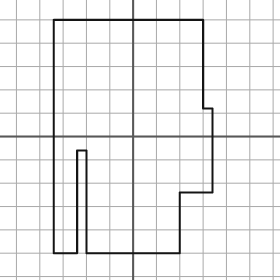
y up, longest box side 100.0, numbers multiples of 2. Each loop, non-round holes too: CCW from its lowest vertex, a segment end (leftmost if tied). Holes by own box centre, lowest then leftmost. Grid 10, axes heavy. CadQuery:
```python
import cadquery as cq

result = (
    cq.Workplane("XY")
    .moveTo(-34.0, -50.0)
    .lineTo(-24.0, -50.0)
    .lineTo(-24.0, -6.0)
    .lineTo(-20.0, -6.0)
    .lineTo(-20.0, -50.0)
    .lineTo(20.0, -50.0)
    .lineTo(20.0, -24.0)
    .lineTo(34.0, -24.0)
    .lineTo(34.0, 12.0)
    .lineTo(30.0, 12.0)
    .lineTo(30.0, 50.0)
    .lineTo(-34.0, 50.0)
    .close()
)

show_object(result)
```